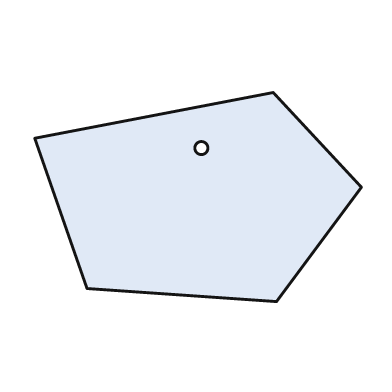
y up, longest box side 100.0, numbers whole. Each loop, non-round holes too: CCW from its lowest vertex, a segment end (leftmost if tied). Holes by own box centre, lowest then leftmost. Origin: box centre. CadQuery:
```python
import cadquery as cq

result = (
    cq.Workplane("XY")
    .moveTo(24.0, -32.0)
    .lineTo(50.0, 3.0)
    .lineTo(23.0, 32.0)
    .lineTo(-50.0, 18.0)
    .lineTo(-34.0, -28.0)
    .close()
    .moveTo(1.0, 15.0)
    .circle(2.0)
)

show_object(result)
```